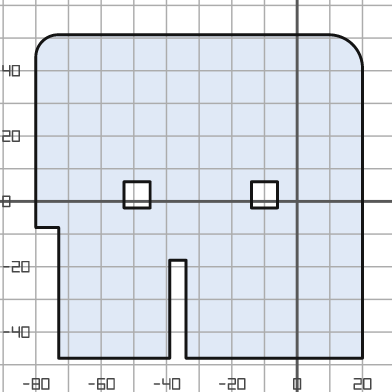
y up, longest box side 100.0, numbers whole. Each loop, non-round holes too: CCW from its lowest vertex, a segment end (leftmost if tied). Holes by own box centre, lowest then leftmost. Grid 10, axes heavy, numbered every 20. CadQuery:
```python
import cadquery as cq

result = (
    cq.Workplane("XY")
    .moveTo(-73.0, -48.0)
    .lineTo(-39.0, -48.0)
    .lineTo(-39.0, -18.0)
    .lineTo(-34.0, -18.0)
    .lineTo(-34.0, -48.0)
    .lineTo(20.0, -48.0)
    .lineTo(20.0, 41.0)
    .threePointArc((17.0, 48.0), (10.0, 51.0))
    .lineTo(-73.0, 51.0)
    .threePointArc((-78.0, 49.0), (-80.0, 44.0))
    .lineTo(-80.0, -8.0)
    .lineTo(-73.0, -8.0)
    .close()
    .moveTo(-53.0, -2.0)
    .lineTo(-45.0, -2.0)
    .lineTo(-45.0, 6.0)
    .lineTo(-53.0, 6.0)
    .close()
    .moveTo(-14.0, -2.0)
    .lineTo(-6.0, -2.0)
    .lineTo(-6.0, 6.0)
    .lineTo(-14.0, 6.0)
    .close()
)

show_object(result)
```